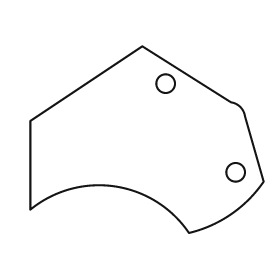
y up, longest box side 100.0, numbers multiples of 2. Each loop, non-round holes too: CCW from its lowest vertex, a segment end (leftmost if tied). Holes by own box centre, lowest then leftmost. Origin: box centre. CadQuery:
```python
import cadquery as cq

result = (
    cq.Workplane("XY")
    .moveTo(18.0, -40.0)
    .threePointArc((36.0, -32.0), (50.0, -18.0))
    .lineTo(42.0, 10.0)
    .threePointArc((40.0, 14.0), (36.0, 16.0))
    .lineTo(-2.0, 40.0)
    .lineTo(-50.0, 8.0)
    .lineTo(-50.0, -30.0)
    .threePointArc((-14.0, -20.0), (18.0, -40.0))
    .close()
    .moveTo(38.0, -14.0)
    .circle(4.0)
    .moveTo(8.0, 24.0)
    .circle(4.0)
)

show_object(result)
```